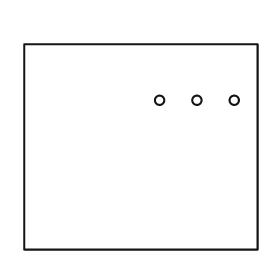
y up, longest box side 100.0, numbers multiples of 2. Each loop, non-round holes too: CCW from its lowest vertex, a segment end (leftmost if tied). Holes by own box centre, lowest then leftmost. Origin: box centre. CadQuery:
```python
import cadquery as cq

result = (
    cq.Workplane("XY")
    .moveTo(-50.0, -44.0)
    .lineTo(50.0, -44.0)
    .lineTo(50.0, 44.0)
    .lineTo(-50.0, 44.0)
    .close()
    .moveTo(8.0, 20.0)
    .circle(2.0)
    .moveTo(24.0, 20.0)
    .circle(2.0)
    .moveTo(40.0, 20.0)
    .circle(2.0)
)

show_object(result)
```